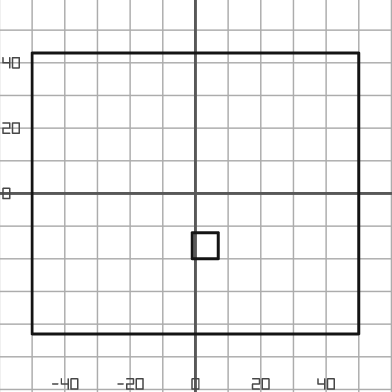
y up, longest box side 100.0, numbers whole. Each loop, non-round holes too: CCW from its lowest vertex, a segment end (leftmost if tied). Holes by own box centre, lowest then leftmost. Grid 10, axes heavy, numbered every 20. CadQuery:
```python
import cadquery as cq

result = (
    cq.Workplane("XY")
    .moveTo(-50.0, -43.0)
    .lineTo(50.0, -43.0)
    .lineTo(50.0, 43.0)
    .lineTo(-50.0, 43.0)
    .close()
    .moveTo(-1.0, -20.0)
    .lineTo(7.0, -20.0)
    .lineTo(7.0, -12.0)
    .lineTo(-1.0, -12.0)
    .close()
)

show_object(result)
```